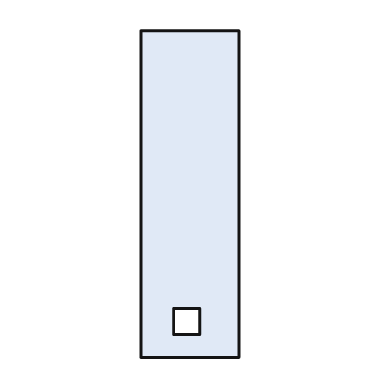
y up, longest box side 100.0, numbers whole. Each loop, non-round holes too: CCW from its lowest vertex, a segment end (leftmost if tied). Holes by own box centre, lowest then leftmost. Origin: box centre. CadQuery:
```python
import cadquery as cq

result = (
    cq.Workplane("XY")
    .moveTo(-15.0, -50.0)
    .lineTo(15.0, -50.0)
    .lineTo(15.0, 50.0)
    .lineTo(-15.0, 50.0)
    .close()
    .moveTo(-5.0, -43.0)
    .lineTo(3.0, -43.0)
    .lineTo(3.0, -35.0)
    .lineTo(-5.0, -35.0)
    .close()
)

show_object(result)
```